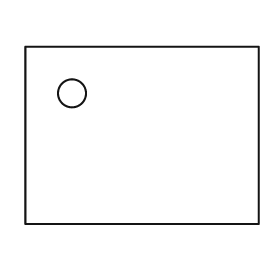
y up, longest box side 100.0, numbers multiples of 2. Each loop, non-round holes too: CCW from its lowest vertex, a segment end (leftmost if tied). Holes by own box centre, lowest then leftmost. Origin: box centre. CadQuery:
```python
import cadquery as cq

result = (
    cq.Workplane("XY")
    .moveTo(-50.0, -38.0)
    .lineTo(50.0, -38.0)
    .lineTo(50.0, 38.0)
    .lineTo(-50.0, 38.0)
    .close()
    .moveTo(-30.0, 18.0)
    .circle(6.0)
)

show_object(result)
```